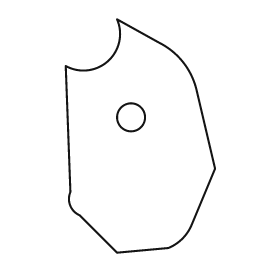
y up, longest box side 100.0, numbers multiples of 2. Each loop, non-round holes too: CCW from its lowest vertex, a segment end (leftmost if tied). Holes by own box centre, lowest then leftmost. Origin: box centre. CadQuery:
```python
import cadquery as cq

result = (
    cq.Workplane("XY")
    .moveTo(-10.0, -50.0)
    .lineTo(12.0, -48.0)
    .threePointArc((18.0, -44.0), (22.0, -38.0))
    .lineTo(32.0, -14.0)
    .lineTo(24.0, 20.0)
    .threePointArc((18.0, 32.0), (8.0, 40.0))
    .lineTo(-10.0, 50.0)
    .threePointArc((-14.0, 32.0), (-32.0, 30.0))
    .lineTo(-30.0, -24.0)
    .threePointArc((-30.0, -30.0), (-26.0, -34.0))
    .close()
    .moveTo(-4.0, 8.0)
    .circle(6.0)
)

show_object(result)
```